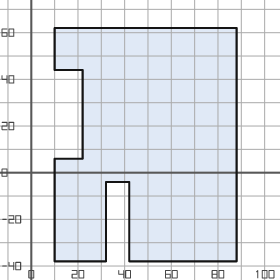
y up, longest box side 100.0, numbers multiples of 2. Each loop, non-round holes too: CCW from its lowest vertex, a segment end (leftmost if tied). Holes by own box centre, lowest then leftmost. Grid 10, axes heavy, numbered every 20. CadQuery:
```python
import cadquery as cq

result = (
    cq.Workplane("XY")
    .moveTo(10.0, -38.0)
    .lineTo(32.0, -38.0)
    .lineTo(32.0, -4.0)
    .lineTo(42.0, -4.0)
    .lineTo(42.0, -38.0)
    .lineTo(88.0, -38.0)
    .lineTo(88.0, 62.0)
    .lineTo(10.0, 62.0)
    .lineTo(10.0, 44.0)
    .lineTo(22.0, 44.0)
    .lineTo(22.0, 6.0)
    .lineTo(10.0, 6.0)
    .close()
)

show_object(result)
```